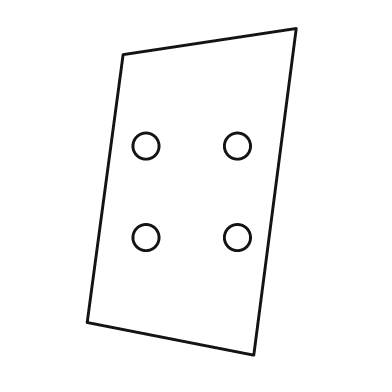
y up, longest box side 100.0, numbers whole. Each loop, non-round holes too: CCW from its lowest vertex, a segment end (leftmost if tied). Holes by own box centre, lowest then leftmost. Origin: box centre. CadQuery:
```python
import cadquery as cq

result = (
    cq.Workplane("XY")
    .moveTo(19.0, -50.0)
    .lineTo(32.0, 50.0)
    .lineTo(-21.0, 42.0)
    .lineTo(-32.0, -40.0)
    .close()
    .moveTo(-14.0, -14.0)
    .circle(4.0)
    .moveTo(14.0, -14.0)
    .circle(4.0)
    .moveTo(-14.0, 14.0)
    .circle(4.0)
    .moveTo(14.0, 14.0)
    .circle(4.0)
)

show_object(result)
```